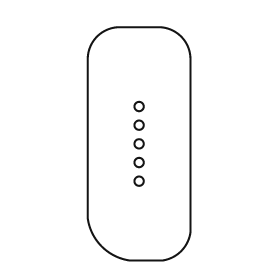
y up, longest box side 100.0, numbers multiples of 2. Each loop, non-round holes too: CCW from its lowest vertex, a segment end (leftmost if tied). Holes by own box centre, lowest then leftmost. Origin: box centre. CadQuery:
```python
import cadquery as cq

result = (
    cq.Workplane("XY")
    .moveTo(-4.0, -50.0)
    .lineTo(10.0, -50.0)
    .threePointArc((18.0, -46.0), (22.0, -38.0))
    .lineTo(22.0, 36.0)
    .threePointArc((18.0, 46.0), (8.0, 50.0))
    .lineTo(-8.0, 50.0)
    .threePointArc((-18.0, 46.0), (-22.0, 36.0))
    .lineTo(-22.0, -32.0)
    .threePointArc((-16.0, -44.0), (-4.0, -50.0))
    .close()
    .moveTo(0.0, -16.0)
    .circle(2.0)
    .moveTo(0.0, -8.0)
    .circle(2.0)
    .moveTo(0.0, 0.0)
    .circle(2.0)
    .moveTo(0.0, 8.0)
    .circle(2.0)
    .moveTo(0.0, 16.0)
    .circle(2.0)
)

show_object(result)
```